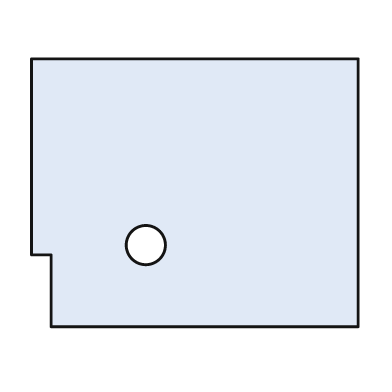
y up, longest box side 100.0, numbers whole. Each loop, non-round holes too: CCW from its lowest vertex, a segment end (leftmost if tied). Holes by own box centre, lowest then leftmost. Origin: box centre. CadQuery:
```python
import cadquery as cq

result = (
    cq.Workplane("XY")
    .moveTo(-44.0, -41.0)
    .lineTo(50.0, -41.0)
    .lineTo(50.0, 41.0)
    .lineTo(-50.0, 41.0)
    .lineTo(-50.0, -19.0)
    .lineTo(-44.0, -19.0)
    .close()
    .moveTo(-15.0, -16.0)
    .circle(6.0)
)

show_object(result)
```